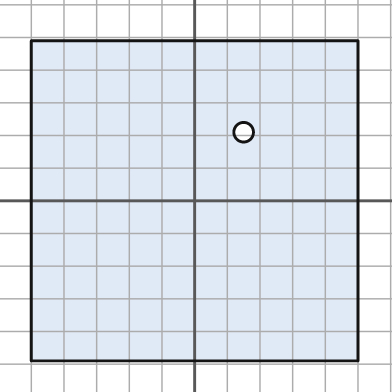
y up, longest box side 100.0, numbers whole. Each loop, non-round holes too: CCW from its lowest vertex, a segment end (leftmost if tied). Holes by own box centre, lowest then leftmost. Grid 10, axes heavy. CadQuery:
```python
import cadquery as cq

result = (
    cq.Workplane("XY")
    .moveTo(-50.0, -49.0)
    .lineTo(50.0, -49.0)
    .lineTo(50.0, 49.0)
    .lineTo(-50.0, 49.0)
    .close()
    .moveTo(15.0, 21.0)
    .circle(3.0)
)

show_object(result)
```